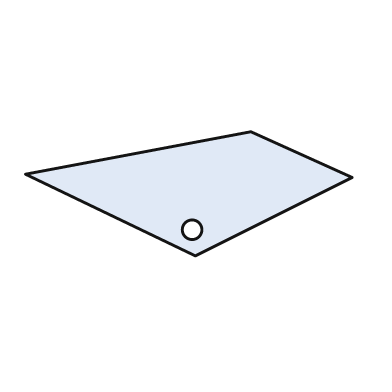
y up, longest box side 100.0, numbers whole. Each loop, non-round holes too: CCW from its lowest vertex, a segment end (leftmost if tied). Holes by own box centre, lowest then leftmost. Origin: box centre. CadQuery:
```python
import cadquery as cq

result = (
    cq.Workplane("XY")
    .moveTo(2.0, -19.0)
    .lineTo(50.0, 5.0)
    .lineTo(19.0, 19.0)
    .lineTo(-50.0, 6.0)
    .close()
    .moveTo(1.0, -11.0)
    .circle(3.0)
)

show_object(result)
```